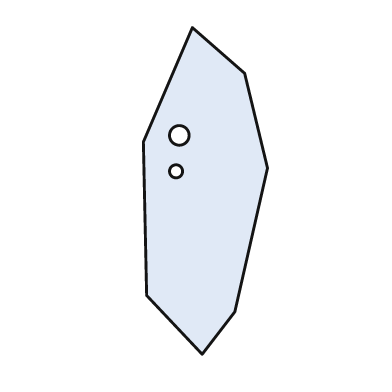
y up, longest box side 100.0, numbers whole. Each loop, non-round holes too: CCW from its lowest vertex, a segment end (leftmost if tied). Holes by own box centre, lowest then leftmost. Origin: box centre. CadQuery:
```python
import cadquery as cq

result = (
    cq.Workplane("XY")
    .moveTo(-1.0, -50.0)
    .lineTo(9.0, -37.0)
    .lineTo(19.0, 7.0)
    .lineTo(12.0, 36.0)
    .lineTo(-4.0, 50.0)
    .lineTo(-19.0, 15.0)
    .lineTo(-18.0, -32.0)
    .close()
    .moveTo(-9.0, 6.0)
    .circle(2.0)
    .moveTo(-8.0, 17.0)
    .circle(3.0)
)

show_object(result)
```